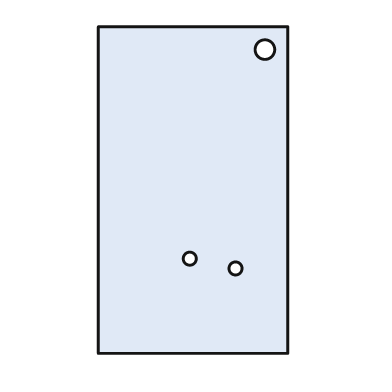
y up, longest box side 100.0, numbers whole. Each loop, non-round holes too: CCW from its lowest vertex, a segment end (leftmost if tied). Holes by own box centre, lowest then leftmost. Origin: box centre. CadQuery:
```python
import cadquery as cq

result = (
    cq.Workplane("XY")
    .moveTo(-29.0, -50.0)
    .lineTo(29.0, -50.0)
    .lineTo(29.0, 50.0)
    .lineTo(-29.0, 50.0)
    .close()
    .moveTo(13.0, -24.0)
    .circle(2.0)
    .moveTo(-1.0, -21.0)
    .circle(2.0)
    .moveTo(22.0, 43.0)
    .circle(3.0)
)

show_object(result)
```